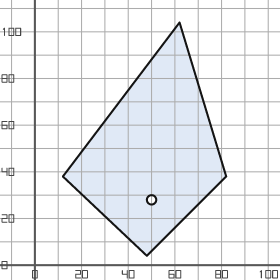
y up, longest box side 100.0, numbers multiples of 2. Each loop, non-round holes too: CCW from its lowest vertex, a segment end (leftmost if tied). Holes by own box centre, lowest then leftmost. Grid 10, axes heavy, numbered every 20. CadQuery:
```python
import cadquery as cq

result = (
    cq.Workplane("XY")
    .moveTo(48.0, 4.0)
    .lineTo(82.0, 38.0)
    .lineTo(62.0, 104.0)
    .lineTo(12.0, 38.0)
    .close()
    .moveTo(50.0, 28.0)
    .circle(2.0)
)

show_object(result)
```